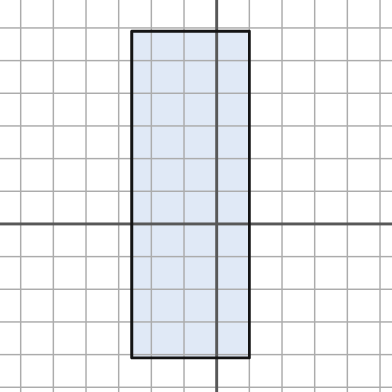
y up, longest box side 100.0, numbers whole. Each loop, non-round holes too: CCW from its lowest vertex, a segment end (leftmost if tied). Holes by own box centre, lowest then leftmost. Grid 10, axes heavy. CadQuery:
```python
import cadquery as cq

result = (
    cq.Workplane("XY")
    .moveTo(-26.0, -41.0)
    .lineTo(10.0, -41.0)
    .lineTo(10.0, 59.0)
    .lineTo(-26.0, 59.0)
    .close()
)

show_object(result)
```